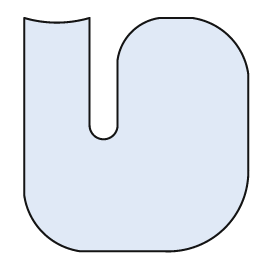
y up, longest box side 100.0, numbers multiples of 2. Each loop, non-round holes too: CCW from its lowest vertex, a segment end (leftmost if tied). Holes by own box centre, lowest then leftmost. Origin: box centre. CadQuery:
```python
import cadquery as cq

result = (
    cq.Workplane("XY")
    .moveTo(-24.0, -50.0)
    .lineTo(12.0, -50.0)
    .threePointArc((38.0, -40.0), (48.0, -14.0))
    .lineTo(48.0, 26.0)
    .threePointArc((40.0, 42.0), (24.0, 50.0))
    .lineTo(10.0, 50.0)
    .threePointArc((-2.0, 44.0), (-8.0, 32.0))
    .lineTo(-8.0, 4.0)
    .threePointArc((-14.0, -2.0), (-20.0, 4.0))
    .lineTo(-20.0, 50.0)
    .threePointArc((-34.0, 48.0), (-48.0, 50.0))
    .lineTo(-48.0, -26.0)
    .threePointArc((-40.0, -42.0), (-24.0, -50.0))
    .close()
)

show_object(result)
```